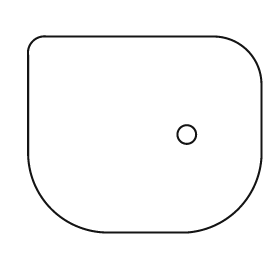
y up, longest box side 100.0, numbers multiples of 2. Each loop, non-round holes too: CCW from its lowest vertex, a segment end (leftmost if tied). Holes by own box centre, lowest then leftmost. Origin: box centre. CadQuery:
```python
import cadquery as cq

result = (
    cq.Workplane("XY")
    .moveTo(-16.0, -42.0)
    .lineTo(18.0, -42.0)
    .threePointArc((40.0, -32.0), (50.0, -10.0))
    .lineTo(50.0, 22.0)
    .threePointArc((44.0, 36.0), (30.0, 42.0))
    .lineTo(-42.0, 42.0)
    .threePointArc((-48.0, 40.0), (-50.0, 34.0))
    .lineTo(-50.0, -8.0)
    .threePointArc((-40.0, -32.0), (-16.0, -42.0))
    .close()
    .moveTo(18.0, 0.0)
    .circle(4.0)
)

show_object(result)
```